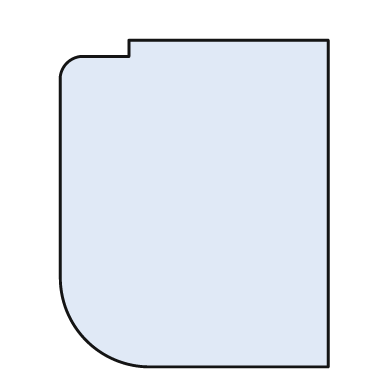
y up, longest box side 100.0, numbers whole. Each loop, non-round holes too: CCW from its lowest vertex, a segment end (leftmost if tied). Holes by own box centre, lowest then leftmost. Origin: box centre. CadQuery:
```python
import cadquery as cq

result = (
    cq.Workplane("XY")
    .moveTo(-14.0, -50.0)
    .lineTo(41.0, -50.0)
    .lineTo(41.0, 50.0)
    .lineTo(-20.0, 50.0)
    .lineTo(-20.0, 45.0)
    .lineTo(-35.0, 45.0)
    .threePointArc((-39.0, 43.0), (-41.0, 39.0))
    .lineTo(-41.0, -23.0)
    .threePointArc((-33.0, -42.0), (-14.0, -50.0))
    .close()
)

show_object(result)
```